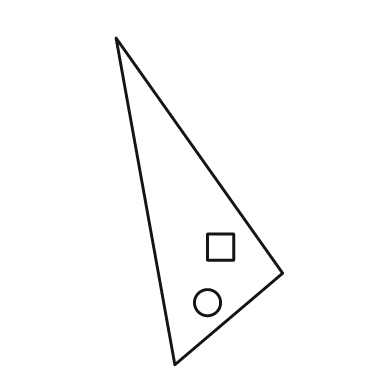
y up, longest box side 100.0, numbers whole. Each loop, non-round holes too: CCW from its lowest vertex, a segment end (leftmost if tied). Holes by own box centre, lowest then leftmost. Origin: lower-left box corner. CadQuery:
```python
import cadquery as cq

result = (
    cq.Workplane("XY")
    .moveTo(18.0, 0.0)
    .lineTo(51.0, 28.0)
    .lineTo(0.0, 100.0)
    .close()
    .moveTo(28.0, 19.0)
    .circle(4.0)
    .moveTo(28.0, 32.0)
    .lineTo(36.0, 32.0)
    .lineTo(36.0, 40.0)
    .lineTo(28.0, 40.0)
    .close()
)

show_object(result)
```